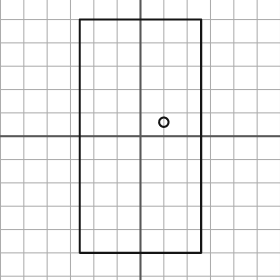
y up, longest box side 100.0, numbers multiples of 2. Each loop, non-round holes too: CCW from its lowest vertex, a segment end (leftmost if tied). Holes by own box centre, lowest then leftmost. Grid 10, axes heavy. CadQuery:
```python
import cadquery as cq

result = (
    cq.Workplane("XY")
    .moveTo(-26.0, -50.0)
    .lineTo(26.0, -50.0)
    .lineTo(26.0, 50.0)
    .lineTo(-26.0, 50.0)
    .close()
    .moveTo(10.0, 6.0)
    .circle(2.0)
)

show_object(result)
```